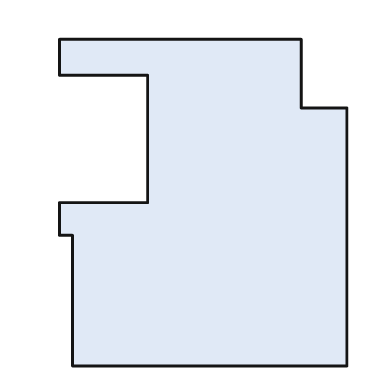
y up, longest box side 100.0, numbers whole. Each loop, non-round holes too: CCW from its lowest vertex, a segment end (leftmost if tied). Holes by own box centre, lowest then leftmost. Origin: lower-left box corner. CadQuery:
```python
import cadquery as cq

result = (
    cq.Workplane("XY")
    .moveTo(4.0, 0.0)
    .lineTo(88.0, 0.0)
    .lineTo(88.0, 79.0)
    .lineTo(74.0, 79.0)
    .lineTo(74.0, 100.0)
    .lineTo(0.0, 100.0)
    .lineTo(0.0, 89.0)
    .lineTo(27.0, 89.0)
    .lineTo(27.0, 50.0)
    .lineTo(0.0, 50.0)
    .lineTo(0.0, 40.0)
    .lineTo(4.0, 40.0)
    .close()
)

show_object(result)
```